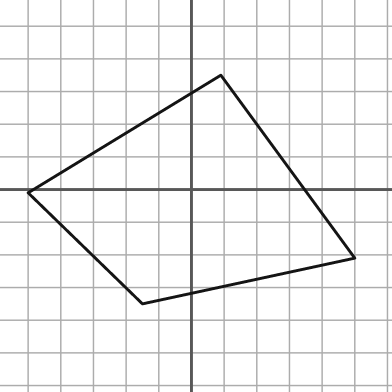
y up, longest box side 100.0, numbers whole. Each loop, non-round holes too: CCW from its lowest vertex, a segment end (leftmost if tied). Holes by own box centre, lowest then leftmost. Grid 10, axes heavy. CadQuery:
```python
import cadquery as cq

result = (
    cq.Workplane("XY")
    .moveTo(-15.0, -35.0)
    .lineTo(50.0, -21.0)
    .lineTo(9.0, 35.0)
    .lineTo(-50.0, -1.0)
    .close()
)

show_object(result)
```